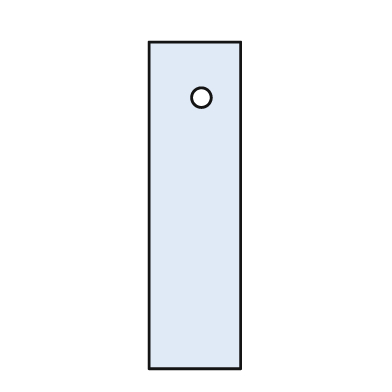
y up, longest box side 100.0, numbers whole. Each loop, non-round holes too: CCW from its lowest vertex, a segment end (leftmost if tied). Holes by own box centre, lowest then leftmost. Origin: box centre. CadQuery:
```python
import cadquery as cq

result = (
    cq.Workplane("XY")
    .moveTo(-14.0, -50.0)
    .lineTo(14.0, -50.0)
    .lineTo(14.0, 50.0)
    .lineTo(-14.0, 50.0)
    .close()
    .moveTo(2.0, 33.0)
    .circle(3.0)
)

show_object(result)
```